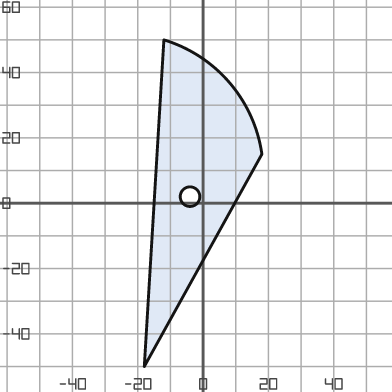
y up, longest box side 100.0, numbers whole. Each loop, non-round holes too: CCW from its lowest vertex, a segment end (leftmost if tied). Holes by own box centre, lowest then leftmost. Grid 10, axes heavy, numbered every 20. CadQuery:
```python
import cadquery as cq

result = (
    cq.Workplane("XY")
    .moveTo(-18.0, -50.0)
    .lineTo(18.0, 15.0)
    .threePointArc((8.0, 37.0), (-12.0, 50.0))
    .close()
    .moveTo(-4.0, 2.0)
    .circle(3.0)
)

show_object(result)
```